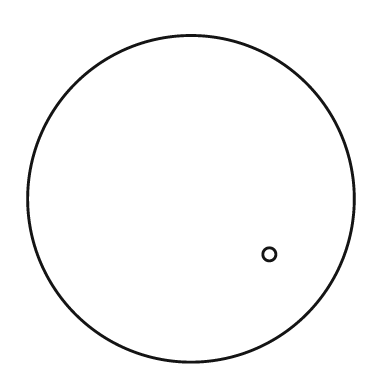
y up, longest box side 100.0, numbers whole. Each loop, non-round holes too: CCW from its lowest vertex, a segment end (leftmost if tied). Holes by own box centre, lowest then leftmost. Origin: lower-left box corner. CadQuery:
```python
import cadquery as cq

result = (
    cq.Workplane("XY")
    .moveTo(50.0, 50.0)
    .circle(50.0)
    .moveTo(74.0, 33.0)
    .circle(2.0)
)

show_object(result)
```